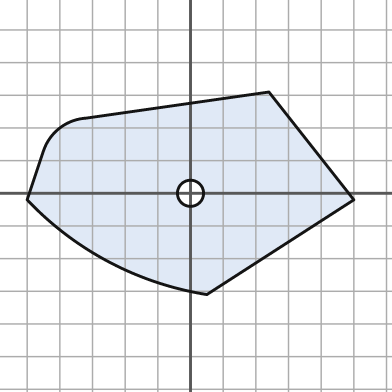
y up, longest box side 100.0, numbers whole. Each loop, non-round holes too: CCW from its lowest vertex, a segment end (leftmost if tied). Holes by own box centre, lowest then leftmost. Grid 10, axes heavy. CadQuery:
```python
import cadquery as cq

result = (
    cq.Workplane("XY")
    .moveTo(5.0, -31.0)
    .lineTo(50.0, -2.0)
    .lineTo(24.0, 31.0)
    .lineTo(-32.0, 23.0)
    .threePointArc((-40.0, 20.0), (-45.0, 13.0))
    .lineTo(-50.0, -2.0)
    .threePointArc((-25.0, -21.0), (5.0, -31.0))
    .close()
    .moveTo(0.0, 0.0)
    .circle(4.0)
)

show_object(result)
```